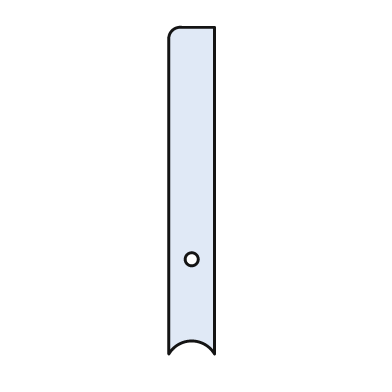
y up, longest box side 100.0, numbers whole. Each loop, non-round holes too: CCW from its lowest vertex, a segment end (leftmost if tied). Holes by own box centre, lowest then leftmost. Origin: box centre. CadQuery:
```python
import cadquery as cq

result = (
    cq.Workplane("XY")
    .moveTo(-7.0, -50.0)
    .threePointArc((0.0, -46.0), (7.0, -50.0))
    .lineTo(7.0, 50.0)
    .lineTo(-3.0, 50.0)
    .threePointArc((-6.0, 49.0), (-7.0, 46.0))
    .close()
    .moveTo(0.0, -21.0)
    .circle(2.0)
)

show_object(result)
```